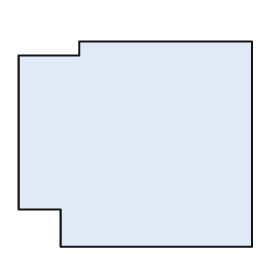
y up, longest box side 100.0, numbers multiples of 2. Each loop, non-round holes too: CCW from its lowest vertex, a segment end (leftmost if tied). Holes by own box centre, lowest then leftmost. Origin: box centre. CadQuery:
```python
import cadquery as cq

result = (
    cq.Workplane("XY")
    .moveTo(-32.0, -44.0)
    .lineTo(50.0, -44.0)
    .lineTo(50.0, 44.0)
    .lineTo(-24.0, 44.0)
    .lineTo(-24.0, 38.0)
    .lineTo(-50.0, 38.0)
    .lineTo(-50.0, -28.0)
    .lineTo(-32.0, -28.0)
    .close()
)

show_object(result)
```